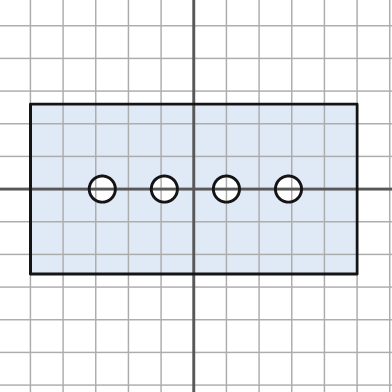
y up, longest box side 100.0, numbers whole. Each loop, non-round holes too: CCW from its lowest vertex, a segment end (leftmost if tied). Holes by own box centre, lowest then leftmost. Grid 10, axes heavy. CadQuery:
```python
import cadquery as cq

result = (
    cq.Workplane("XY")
    .moveTo(-50.0, -26.0)
    .lineTo(50.0, -26.0)
    .lineTo(50.0, 26.0)
    .lineTo(-50.0, 26.0)
    .close()
    .moveTo(-28.0, 0.0)
    .circle(4.0)
    .moveTo(-9.0, 0.0)
    .circle(4.0)
    .moveTo(10.0, 0.0)
    .circle(4.0)
    .moveTo(29.0, 0.0)
    .circle(4.0)
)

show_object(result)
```